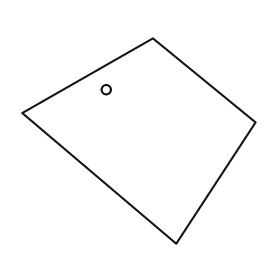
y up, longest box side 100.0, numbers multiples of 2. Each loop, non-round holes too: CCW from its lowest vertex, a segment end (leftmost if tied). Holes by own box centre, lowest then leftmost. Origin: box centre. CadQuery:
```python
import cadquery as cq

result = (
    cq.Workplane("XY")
    .moveTo(16.0, -44.0)
    .lineTo(50.0, 8.0)
    .lineTo(6.0, 44.0)
    .lineTo(-50.0, 12.0)
    .close()
    .moveTo(-14.0, 22.0)
    .circle(2.0)
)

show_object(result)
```